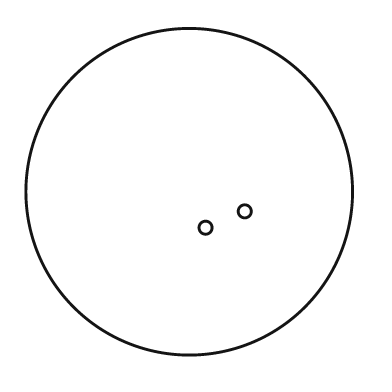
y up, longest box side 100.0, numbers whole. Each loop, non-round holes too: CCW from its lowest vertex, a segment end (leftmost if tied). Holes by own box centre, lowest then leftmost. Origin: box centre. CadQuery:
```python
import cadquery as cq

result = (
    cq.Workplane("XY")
    .moveTo(0.0, 0.0)
    .circle(50.0)
    .moveTo(5.0, -11.0)
    .circle(2.0)
    .moveTo(17.0, -6.0)
    .circle(2.0)
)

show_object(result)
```